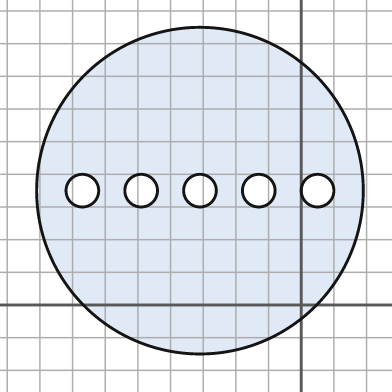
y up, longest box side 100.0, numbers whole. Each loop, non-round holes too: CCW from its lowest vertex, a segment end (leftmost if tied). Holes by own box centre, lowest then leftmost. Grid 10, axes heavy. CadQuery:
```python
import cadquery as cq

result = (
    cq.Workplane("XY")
    .moveTo(-31.0, 35.0)
    .circle(50.0)
    .moveTo(-67.0, 35.0)
    .circle(5.0)
    .moveTo(-49.0, 35.0)
    .circle(5.0)
    .moveTo(-31.0, 35.0)
    .circle(5.0)
    .moveTo(-13.0, 35.0)
    .circle(5.0)
    .moveTo(5.0, 35.0)
    .circle(5.0)
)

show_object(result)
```